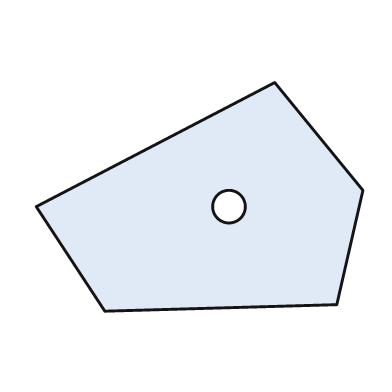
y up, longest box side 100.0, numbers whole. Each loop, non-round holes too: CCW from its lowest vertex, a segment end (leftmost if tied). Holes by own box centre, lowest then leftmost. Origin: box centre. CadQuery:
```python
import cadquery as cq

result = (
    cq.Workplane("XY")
    .moveTo(-29.0, -35.0)
    .lineTo(42.0, -33.0)
    .lineTo(50.0, 2.0)
    .lineTo(23.0, 35.0)
    .lineTo(-50.0, -3.0)
    .close()
    .moveTo(9.0, -3.0)
    .circle(5.0)
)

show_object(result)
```